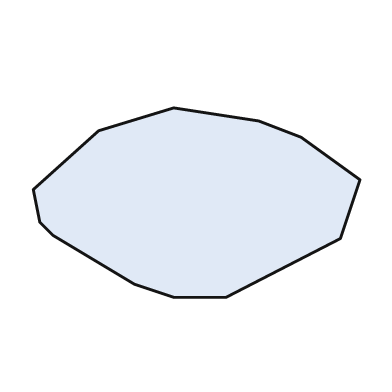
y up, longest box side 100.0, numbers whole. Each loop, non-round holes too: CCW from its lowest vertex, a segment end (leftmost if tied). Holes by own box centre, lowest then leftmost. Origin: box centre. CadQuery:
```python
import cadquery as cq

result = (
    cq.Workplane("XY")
    .moveTo(-7.0, -29.0)
    .lineTo(9.0, -29.0)
    .lineTo(44.0, -11.0)
    .lineTo(50.0, 7.0)
    .lineTo(32.0, 20.0)
    .lineTo(19.0, 25.0)
    .lineTo(-7.0, 29.0)
    .lineTo(-30.0, 22.0)
    .lineTo(-50.0, 4.0)
    .lineTo(-48.0, -6.0)
    .lineTo(-44.0, -10.0)
    .lineTo(-19.0, -25.0)
    .close()
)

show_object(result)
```